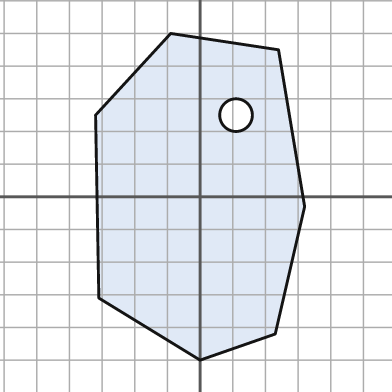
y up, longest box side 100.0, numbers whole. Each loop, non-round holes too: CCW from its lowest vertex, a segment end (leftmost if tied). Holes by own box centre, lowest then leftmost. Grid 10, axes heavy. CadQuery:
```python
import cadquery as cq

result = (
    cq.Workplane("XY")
    .moveTo(0.0, -50.0)
    .lineTo(23.0, -42.0)
    .lineTo(32.0, -3.0)
    .lineTo(24.0, 45.0)
    .lineTo(-9.0, 50.0)
    .lineTo(-32.0, 25.0)
    .lineTo(-31.0, -31.0)
    .close()
    .moveTo(11.0, 25.0)
    .circle(5.0)
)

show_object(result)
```